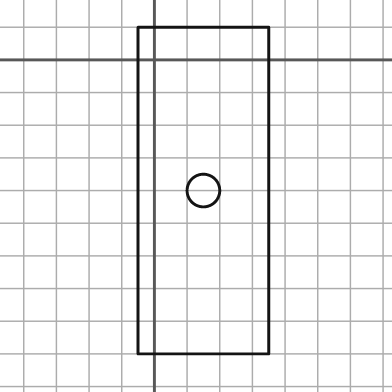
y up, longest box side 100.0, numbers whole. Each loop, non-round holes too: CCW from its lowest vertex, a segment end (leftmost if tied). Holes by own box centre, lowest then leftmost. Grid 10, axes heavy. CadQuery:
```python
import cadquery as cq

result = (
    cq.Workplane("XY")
    .moveTo(-5.0, -90.0)
    .lineTo(35.0, -90.0)
    .lineTo(35.0, 10.0)
    .lineTo(-5.0, 10.0)
    .close()
    .moveTo(15.0, -40.0)
    .circle(5.0)
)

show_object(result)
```